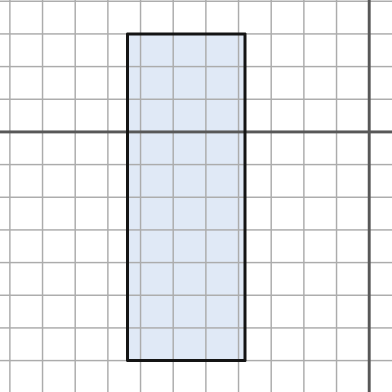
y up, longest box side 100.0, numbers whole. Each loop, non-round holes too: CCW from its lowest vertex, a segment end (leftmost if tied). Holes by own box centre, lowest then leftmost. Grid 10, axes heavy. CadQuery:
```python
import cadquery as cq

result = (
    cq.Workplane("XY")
    .moveTo(-74.0, -70.0)
    .lineTo(-38.0, -70.0)
    .lineTo(-38.0, 30.0)
    .lineTo(-74.0, 30.0)
    .close()
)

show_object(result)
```